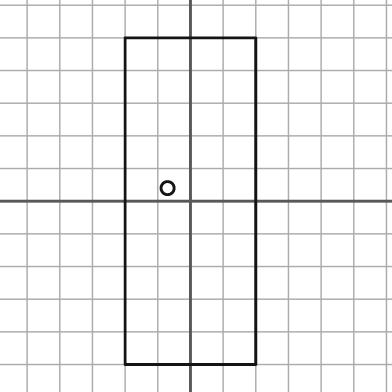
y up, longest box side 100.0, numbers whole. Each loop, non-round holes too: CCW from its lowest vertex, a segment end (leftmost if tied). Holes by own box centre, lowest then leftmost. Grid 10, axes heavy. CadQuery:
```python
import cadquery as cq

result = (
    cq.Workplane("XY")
    .moveTo(-20.0, -50.0)
    .lineTo(20.0, -50.0)
    .lineTo(20.0, 50.0)
    .lineTo(-20.0, 50.0)
    .close()
    .moveTo(-7.0, 4.0)
    .circle(2.0)
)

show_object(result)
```